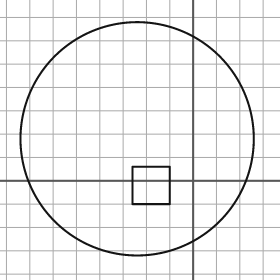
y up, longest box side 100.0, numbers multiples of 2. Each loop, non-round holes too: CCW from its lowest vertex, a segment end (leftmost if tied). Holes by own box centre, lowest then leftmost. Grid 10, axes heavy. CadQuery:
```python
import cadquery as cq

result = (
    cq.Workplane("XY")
    .moveTo(-24.0, 18.0)
    .circle(50.0)
    .moveTo(-26.0, -10.0)
    .lineTo(-10.0, -10.0)
    .lineTo(-10.0, 6.0)
    .lineTo(-26.0, 6.0)
    .close()
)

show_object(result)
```